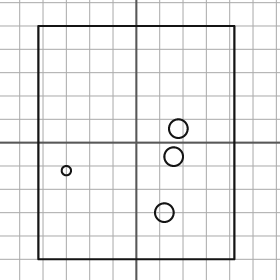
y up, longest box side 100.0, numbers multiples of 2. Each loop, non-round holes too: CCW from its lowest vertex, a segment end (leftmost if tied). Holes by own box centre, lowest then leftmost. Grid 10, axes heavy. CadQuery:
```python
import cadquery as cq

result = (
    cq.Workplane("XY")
    .moveTo(-42.0, -50.0)
    .lineTo(42.0, -50.0)
    .lineTo(42.0, 50.0)
    .lineTo(-42.0, 50.0)
    .close()
    .moveTo(12.0, -30.0)
    .circle(4.0)
    .moveTo(-30.0, -12.0)
    .circle(2.0)
    .moveTo(16.0, -6.0)
    .circle(4.0)
    .moveTo(18.0, 6.0)
    .circle(4.0)
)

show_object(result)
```